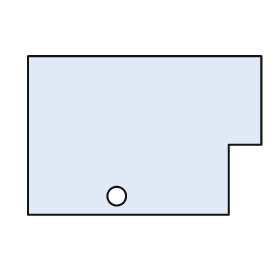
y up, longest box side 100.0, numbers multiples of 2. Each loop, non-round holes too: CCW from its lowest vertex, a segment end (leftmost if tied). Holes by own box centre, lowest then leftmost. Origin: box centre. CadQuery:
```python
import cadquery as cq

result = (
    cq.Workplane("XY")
    .moveTo(-50.0, -34.0)
    .lineTo(36.0, -34.0)
    .lineTo(36.0, -4.0)
    .lineTo(50.0, -4.0)
    .lineTo(50.0, 34.0)
    .lineTo(-50.0, 34.0)
    .close()
    .moveTo(-12.0, -26.0)
    .circle(4.0)
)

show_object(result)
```